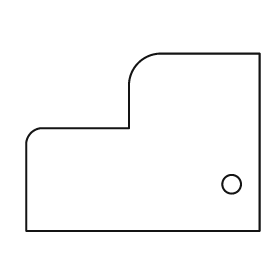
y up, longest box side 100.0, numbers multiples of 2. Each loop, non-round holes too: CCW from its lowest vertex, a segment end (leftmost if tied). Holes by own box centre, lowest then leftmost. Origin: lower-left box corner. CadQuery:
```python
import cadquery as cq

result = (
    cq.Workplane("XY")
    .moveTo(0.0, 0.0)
    .lineTo(100.0, 0.0)
    .lineTo(100.0, 76.0)
    .lineTo(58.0, 76.0)
    .threePointArc((48.0, 72.0), (44.0, 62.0))
    .lineTo(44.0, 44.0)
    .lineTo(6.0, 44.0)
    .threePointArc((2.0, 42.0), (0.0, 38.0))
    .close()
    .moveTo(88.0, 20.0)
    .circle(4.0)
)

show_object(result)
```